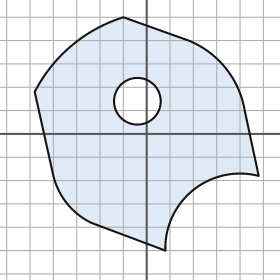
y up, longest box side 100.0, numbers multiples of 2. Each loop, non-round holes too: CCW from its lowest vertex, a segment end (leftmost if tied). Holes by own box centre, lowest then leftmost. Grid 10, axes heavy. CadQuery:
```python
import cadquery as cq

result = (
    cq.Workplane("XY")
    .moveTo(8.0, -50.0)
    .threePointArc((20.0, -24.0), (48.0, -18.0))
    .lineTo(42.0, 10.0)
    .threePointArc((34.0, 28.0), (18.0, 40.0))
    .lineTo(-10.0, 50.0)
    .threePointArc((-32.0, 38.0), (-48.0, 18.0))
    .lineTo(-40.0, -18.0)
    .threePointArc((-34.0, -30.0), (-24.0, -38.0))
    .close()
    .moveTo(-4.0, 14.0)
    .circle(10.0)
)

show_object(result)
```